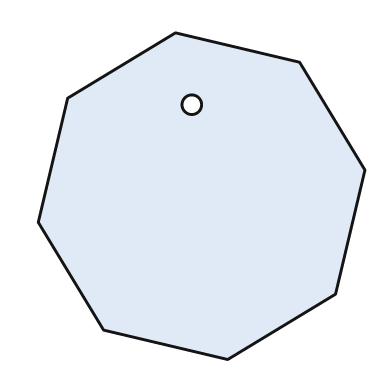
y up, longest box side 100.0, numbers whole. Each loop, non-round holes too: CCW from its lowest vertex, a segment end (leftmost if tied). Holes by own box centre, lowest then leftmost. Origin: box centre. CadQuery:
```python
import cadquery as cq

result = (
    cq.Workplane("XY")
    .moveTo(8.0, -50.0)
    .lineTo(41.0, -30.0)
    .lineTo(50.0, 8.0)
    .lineTo(30.0, 41.0)
    .lineTo(-8.0, 50.0)
    .lineTo(-41.0, 30.0)
    .lineTo(-50.0, -8.0)
    .lineTo(-30.0, -41.0)
    .close()
    .moveTo(-3.0, 28.0)
    .circle(3.0)
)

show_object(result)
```